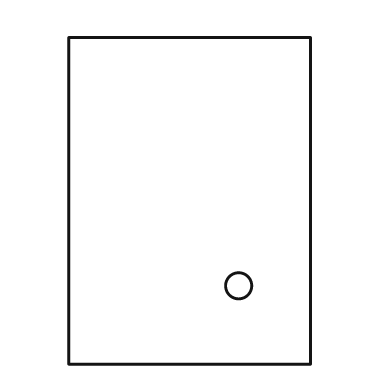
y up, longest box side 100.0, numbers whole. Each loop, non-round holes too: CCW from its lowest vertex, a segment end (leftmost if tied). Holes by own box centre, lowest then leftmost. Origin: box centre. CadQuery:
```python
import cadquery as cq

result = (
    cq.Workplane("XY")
    .moveTo(-37.0, -50.0)
    .lineTo(37.0, -50.0)
    .lineTo(37.0, 50.0)
    .lineTo(-37.0, 50.0)
    .close()
    .moveTo(15.0, -26.0)
    .circle(4.0)
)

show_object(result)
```